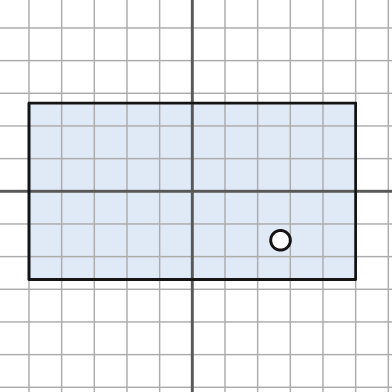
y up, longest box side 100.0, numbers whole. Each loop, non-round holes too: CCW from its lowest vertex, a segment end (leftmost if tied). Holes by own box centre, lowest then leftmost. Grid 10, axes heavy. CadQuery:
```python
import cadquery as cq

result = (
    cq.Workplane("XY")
    .moveTo(-50.0, -27.0)
    .lineTo(50.0, -27.0)
    .lineTo(50.0, 27.0)
    .lineTo(-50.0, 27.0)
    .close()
    .moveTo(27.0, -15.0)
    .circle(3.0)
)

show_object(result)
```